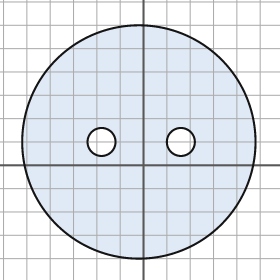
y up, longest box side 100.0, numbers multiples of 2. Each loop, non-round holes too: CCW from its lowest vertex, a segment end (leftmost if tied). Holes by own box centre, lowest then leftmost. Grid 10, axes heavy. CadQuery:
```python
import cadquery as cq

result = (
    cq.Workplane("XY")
    .moveTo(-2.0, 10.0)
    .circle(50.0)
    .moveTo(-18.0, 10.0)
    .circle(6.0)
    .moveTo(16.0, 10.0)
    .circle(6.0)
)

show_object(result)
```